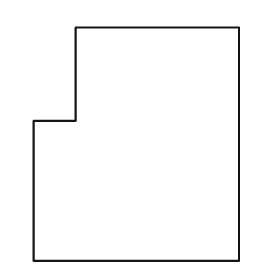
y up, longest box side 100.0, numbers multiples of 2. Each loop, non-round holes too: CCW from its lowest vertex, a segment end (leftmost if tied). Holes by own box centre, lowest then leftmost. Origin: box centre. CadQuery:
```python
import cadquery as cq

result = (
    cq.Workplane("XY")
    .moveTo(-44.0, -50.0)
    .lineTo(44.0, -50.0)
    .lineTo(44.0, 50.0)
    .lineTo(-26.0, 50.0)
    .lineTo(-26.0, 10.0)
    .lineTo(-44.0, 10.0)
    .close()
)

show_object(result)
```